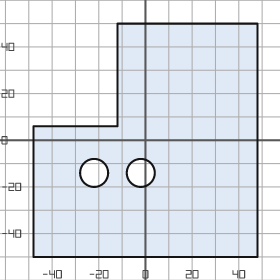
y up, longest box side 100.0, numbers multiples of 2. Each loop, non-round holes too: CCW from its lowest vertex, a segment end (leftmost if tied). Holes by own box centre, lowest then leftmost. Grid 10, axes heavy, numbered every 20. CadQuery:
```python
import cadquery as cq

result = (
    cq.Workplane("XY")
    .moveTo(-48.0, -50.0)
    .lineTo(48.0, -50.0)
    .lineTo(48.0, 50.0)
    .lineTo(-12.0, 50.0)
    .lineTo(-12.0, 6.0)
    .lineTo(-48.0, 6.0)
    .close()
    .moveTo(-22.0, -14.0)
    .circle(6.0)
    .moveTo(-2.0, -14.0)
    .circle(6.0)
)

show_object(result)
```